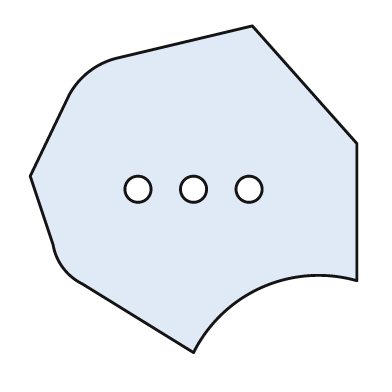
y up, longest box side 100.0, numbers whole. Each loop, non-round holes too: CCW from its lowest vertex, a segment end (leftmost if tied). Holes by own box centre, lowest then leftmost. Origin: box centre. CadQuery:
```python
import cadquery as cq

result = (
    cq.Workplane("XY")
    .moveTo(0.0, -50.0)
    .threePointArc((21.0, -30.0), (50.0, -28.0))
    .lineTo(50.0, 14.0)
    .lineTo(18.0, 50.0)
    .lineTo(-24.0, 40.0)
    .threePointArc((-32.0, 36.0), (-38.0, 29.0))
    .lineTo(-50.0, 4.0)
    .lineTo(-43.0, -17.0)
    .threePointArc((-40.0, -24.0), (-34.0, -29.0))
    .close()
    .moveTo(-17.0, 0.0)
    .circle(4.0)
    .moveTo(0.0, 0.0)
    .circle(4.0)
    .moveTo(17.0, 0.0)
    .circle(4.0)
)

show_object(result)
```